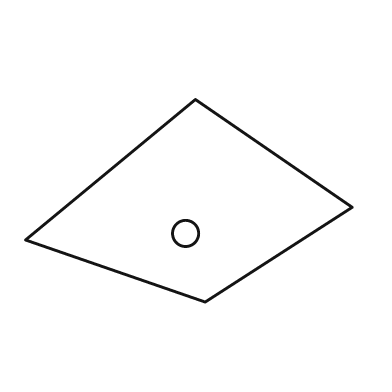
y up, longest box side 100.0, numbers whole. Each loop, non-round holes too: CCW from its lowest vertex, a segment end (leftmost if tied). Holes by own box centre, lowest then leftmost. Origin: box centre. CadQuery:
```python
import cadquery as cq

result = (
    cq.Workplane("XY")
    .moveTo(5.0, -31.0)
    .lineTo(50.0, -2.0)
    .lineTo(2.0, 31.0)
    .lineTo(-50.0, -12.0)
    .close()
    .moveTo(-1.0, -10.0)
    .circle(4.0)
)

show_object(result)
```